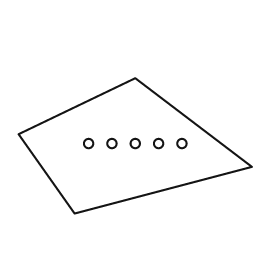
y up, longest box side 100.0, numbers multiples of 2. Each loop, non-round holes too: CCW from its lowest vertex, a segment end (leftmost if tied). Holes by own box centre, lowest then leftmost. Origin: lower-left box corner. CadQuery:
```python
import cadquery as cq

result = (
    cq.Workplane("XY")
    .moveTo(24.0, 0.0)
    .lineTo(100.0, 20.0)
    .lineTo(50.0, 58.0)
    .lineTo(0.0, 34.0)
    .close()
    .moveTo(30.0, 30.0)
    .circle(2.0)
    .moveTo(40.0, 30.0)
    .circle(2.0)
    .moveTo(50.0, 30.0)
    .circle(2.0)
    .moveTo(60.0, 30.0)
    .circle(2.0)
    .moveTo(70.0, 30.0)
    .circle(2.0)
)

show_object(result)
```